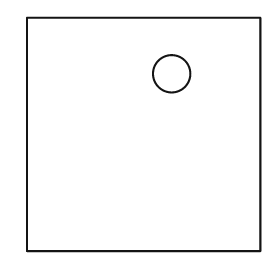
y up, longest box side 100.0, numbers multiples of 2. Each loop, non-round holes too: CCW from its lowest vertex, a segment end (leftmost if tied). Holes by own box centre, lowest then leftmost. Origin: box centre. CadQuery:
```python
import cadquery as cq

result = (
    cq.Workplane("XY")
    .moveTo(-50.0, -50.0)
    .lineTo(50.0, -50.0)
    .lineTo(50.0, 50.0)
    .lineTo(-50.0, 50.0)
    .close()
    .moveTo(12.0, 26.0)
    .circle(8.0)
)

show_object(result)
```